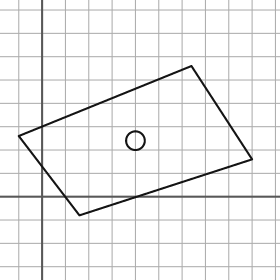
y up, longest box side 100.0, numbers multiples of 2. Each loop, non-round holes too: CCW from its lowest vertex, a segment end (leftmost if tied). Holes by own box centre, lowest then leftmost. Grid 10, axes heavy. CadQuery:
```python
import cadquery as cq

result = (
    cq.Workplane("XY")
    .moveTo(16.0, -8.0)
    .lineTo(90.0, 16.0)
    .lineTo(64.0, 56.0)
    .lineTo(-10.0, 26.0)
    .close()
    .moveTo(40.0, 24.0)
    .circle(4.0)
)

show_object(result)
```